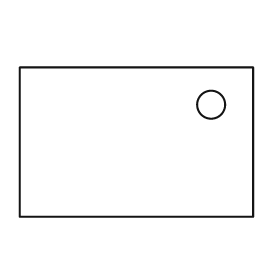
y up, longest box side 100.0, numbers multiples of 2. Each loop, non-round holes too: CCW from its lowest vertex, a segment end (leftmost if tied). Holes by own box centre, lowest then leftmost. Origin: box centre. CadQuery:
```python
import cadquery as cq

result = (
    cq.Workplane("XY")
    .moveTo(-50.0, -32.0)
    .lineTo(50.0, -32.0)
    .lineTo(50.0, 32.0)
    .lineTo(-50.0, 32.0)
    .close()
    .moveTo(32.0, 16.0)
    .circle(6.0)
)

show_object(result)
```